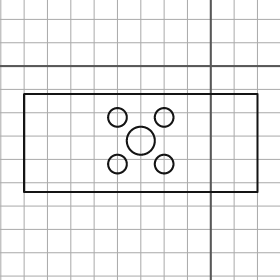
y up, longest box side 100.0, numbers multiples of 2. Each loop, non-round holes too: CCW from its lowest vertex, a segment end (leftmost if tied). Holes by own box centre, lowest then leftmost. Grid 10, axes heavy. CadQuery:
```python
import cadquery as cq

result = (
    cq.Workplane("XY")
    .moveTo(-80.0, -54.0)
    .lineTo(20.0, -54.0)
    .lineTo(20.0, -12.0)
    .lineTo(-80.0, -12.0)
    .close()
    .moveTo(-40.0, -42.0)
    .circle(4.0)
    .moveTo(-20.0, -42.0)
    .circle(4.0)
    .moveTo(-30.0, -32.0)
    .circle(6.0)
    .moveTo(-40.0, -22.0)
    .circle(4.0)
    .moveTo(-20.0, -22.0)
    .circle(4.0)
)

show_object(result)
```